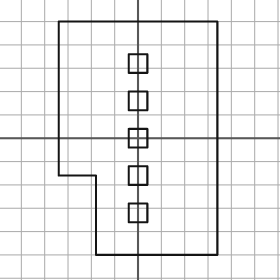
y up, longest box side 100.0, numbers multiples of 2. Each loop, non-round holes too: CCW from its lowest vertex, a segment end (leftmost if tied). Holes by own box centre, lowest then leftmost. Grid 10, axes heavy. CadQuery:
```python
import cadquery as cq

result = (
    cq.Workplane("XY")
    .moveTo(-18.0, -50.0)
    .lineTo(34.0, -50.0)
    .lineTo(34.0, 50.0)
    .lineTo(-34.0, 50.0)
    .lineTo(-34.0, -16.0)
    .lineTo(-18.0, -16.0)
    .close()
    .moveTo(-4.0, -36.0)
    .lineTo(4.0, -36.0)
    .lineTo(4.0, -28.0)
    .lineTo(-4.0, -28.0)
    .close()
    .moveTo(-4.0, -20.0)
    .lineTo(4.0, -20.0)
    .lineTo(4.0, -12.0)
    .lineTo(-4.0, -12.0)
    .close()
    .moveTo(-4.0, -4.0)
    .lineTo(4.0, -4.0)
    .lineTo(4.0, 4.0)
    .lineTo(-4.0, 4.0)
    .close()
    .moveTo(-4.0, 12.0)
    .lineTo(4.0, 12.0)
    .lineTo(4.0, 20.0)
    .lineTo(-4.0, 20.0)
    .close()
    .moveTo(-4.0, 28.0)
    .lineTo(4.0, 28.0)
    .lineTo(4.0, 36.0)
    .lineTo(-4.0, 36.0)
    .close()
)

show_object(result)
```